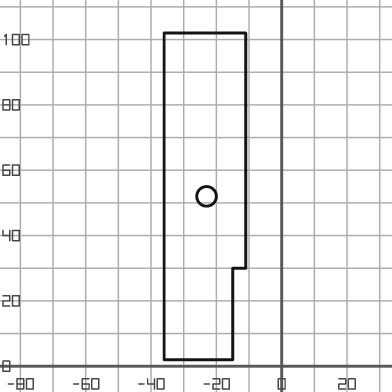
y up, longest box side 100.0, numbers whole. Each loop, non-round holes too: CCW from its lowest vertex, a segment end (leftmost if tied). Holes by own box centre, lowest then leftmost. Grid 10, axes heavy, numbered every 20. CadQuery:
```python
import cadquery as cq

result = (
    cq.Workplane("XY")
    .moveTo(-36.0, 2.0)
    .lineTo(-15.0, 2.0)
    .lineTo(-15.0, 30.0)
    .lineTo(-11.0, 30.0)
    .lineTo(-11.0, 102.0)
    .lineTo(-36.0, 102.0)
    .close()
    .moveTo(-23.0, 52.0)
    .circle(3.0)
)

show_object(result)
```